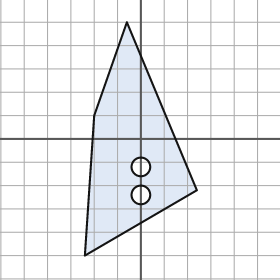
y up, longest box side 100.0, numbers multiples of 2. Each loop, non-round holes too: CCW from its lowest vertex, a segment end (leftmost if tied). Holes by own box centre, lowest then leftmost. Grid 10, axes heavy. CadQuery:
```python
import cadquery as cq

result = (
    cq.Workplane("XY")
    .moveTo(-24.0, -50.0)
    .lineTo(24.0, -22.0)
    .lineTo(-6.0, 50.0)
    .lineTo(-20.0, 10.0)
    .close()
    .moveTo(0.0, -24.0)
    .circle(4.0)
    .moveTo(0.0, -12.0)
    .circle(4.0)
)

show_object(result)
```